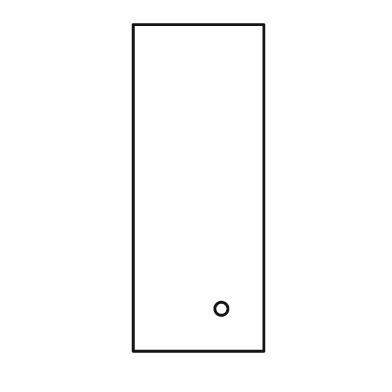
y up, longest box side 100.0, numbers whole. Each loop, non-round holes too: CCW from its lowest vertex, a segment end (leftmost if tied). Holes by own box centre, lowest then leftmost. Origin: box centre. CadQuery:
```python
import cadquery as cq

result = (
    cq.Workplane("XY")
    .moveTo(-20.0, -50.0)
    .lineTo(20.0, -50.0)
    .lineTo(20.0, 50.0)
    .lineTo(-20.0, 50.0)
    .close()
    .moveTo(7.0, -37.0)
    .circle(2.0)
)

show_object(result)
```